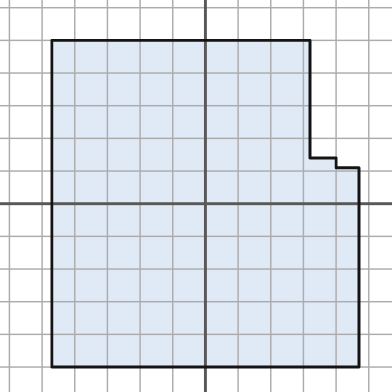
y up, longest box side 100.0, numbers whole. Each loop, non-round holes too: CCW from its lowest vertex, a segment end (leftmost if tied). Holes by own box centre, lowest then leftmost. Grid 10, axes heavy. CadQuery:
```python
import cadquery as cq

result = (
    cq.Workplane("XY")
    .moveTo(-47.0, -50.0)
    .lineTo(47.0, -50.0)
    .lineTo(47.0, 11.0)
    .lineTo(40.0, 11.0)
    .lineTo(40.0, 14.0)
    .lineTo(32.0, 14.0)
    .lineTo(32.0, 50.0)
    .lineTo(-47.0, 50.0)
    .close()
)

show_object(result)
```